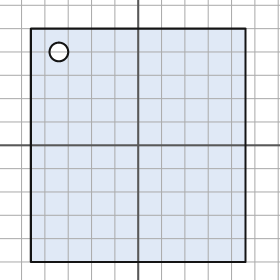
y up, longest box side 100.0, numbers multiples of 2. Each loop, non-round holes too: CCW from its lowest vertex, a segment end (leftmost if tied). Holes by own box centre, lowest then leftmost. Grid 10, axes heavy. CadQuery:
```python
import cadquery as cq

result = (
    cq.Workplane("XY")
    .moveTo(-46.0, -50.0)
    .lineTo(46.0, -50.0)
    .lineTo(46.0, 50.0)
    .lineTo(-46.0, 50.0)
    .close()
    .moveTo(-34.0, 40.0)
    .circle(4.0)
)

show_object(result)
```